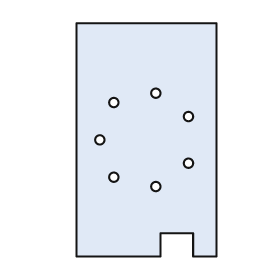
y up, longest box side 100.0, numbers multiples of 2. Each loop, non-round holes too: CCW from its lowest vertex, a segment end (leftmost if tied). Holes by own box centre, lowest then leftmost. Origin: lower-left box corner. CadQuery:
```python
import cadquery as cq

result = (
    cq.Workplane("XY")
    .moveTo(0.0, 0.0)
    .lineTo(36.0, 0.0)
    .lineTo(36.0, 10.0)
    .lineTo(50.0, 10.0)
    .lineTo(50.0, 0.0)
    .lineTo(60.0, 0.0)
    .lineTo(60.0, 100.0)
    .lineTo(0.0, 100.0)
    .close()
    .moveTo(34.0, 30.0)
    .circle(2.0)
    .moveTo(16.0, 34.0)
    .circle(2.0)
    .moveTo(48.0, 40.0)
    .circle(2.0)
    .moveTo(10.0, 50.0)
    .circle(2.0)
    .moveTo(48.0, 60.0)
    .circle(2.0)
    .moveTo(16.0, 66.0)
    .circle(2.0)
    .moveTo(34.0, 70.0)
    .circle(2.0)
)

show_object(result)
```